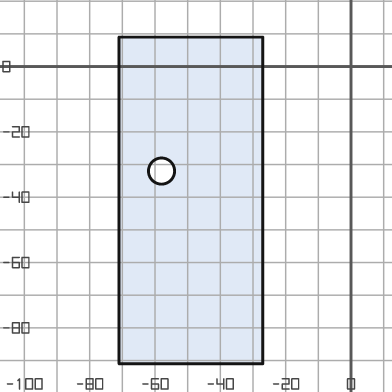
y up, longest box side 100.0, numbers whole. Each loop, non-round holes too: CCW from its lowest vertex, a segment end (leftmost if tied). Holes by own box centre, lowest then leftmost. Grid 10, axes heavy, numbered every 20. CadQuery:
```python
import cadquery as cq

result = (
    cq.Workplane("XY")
    .moveTo(-71.0, -91.0)
    .lineTo(-27.0, -91.0)
    .lineTo(-27.0, 9.0)
    .lineTo(-71.0, 9.0)
    .close()
    .moveTo(-58.0, -32.0)
    .circle(4.0)
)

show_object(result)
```